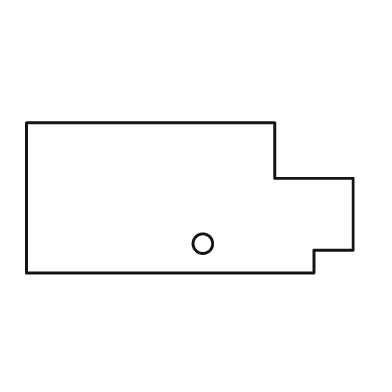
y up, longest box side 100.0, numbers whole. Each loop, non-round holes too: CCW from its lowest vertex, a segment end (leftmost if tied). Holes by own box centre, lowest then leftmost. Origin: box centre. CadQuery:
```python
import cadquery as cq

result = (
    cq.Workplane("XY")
    .moveTo(-50.0, -23.0)
    .lineTo(38.0, -23.0)
    .lineTo(38.0, -16.0)
    .lineTo(50.0, -16.0)
    .lineTo(50.0, 6.0)
    .lineTo(26.0, 6.0)
    .lineTo(26.0, 23.0)
    .lineTo(-50.0, 23.0)
    .close()
    .moveTo(4.0, -14.0)
    .circle(3.0)
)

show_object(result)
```